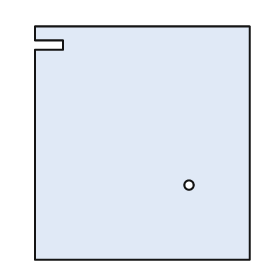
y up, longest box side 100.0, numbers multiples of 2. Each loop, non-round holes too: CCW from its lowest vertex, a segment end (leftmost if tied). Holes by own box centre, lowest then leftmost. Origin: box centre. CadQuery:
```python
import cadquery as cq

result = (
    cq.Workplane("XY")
    .moveTo(-46.0, -50.0)
    .lineTo(46.0, -50.0)
    .lineTo(46.0, 50.0)
    .lineTo(-46.0, 50.0)
    .lineTo(-46.0, 44.0)
    .lineTo(-34.0, 44.0)
    .lineTo(-34.0, 40.0)
    .lineTo(-46.0, 40.0)
    .close()
    .moveTo(20.0, -18.0)
    .circle(2.0)
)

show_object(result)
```